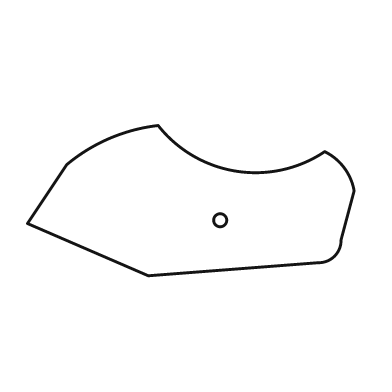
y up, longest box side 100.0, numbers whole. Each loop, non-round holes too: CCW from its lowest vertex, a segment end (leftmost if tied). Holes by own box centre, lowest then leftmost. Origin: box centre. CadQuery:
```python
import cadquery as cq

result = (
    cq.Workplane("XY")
    .moveTo(-13.0, -23.0)
    .lineTo(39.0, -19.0)
    .threePointArc((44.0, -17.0), (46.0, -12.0))
    .lineTo(50.0, 3.0)
    .threePointArc((47.0, 10.0), (41.0, 15.0))
    .threePointArc((14.0, 9.0), (-10.0, 23.0))
    .threePointArc((-25.0, 19.0), (-38.0, 11.0))
    .lineTo(-50.0, -7.0)
    .close()
    .moveTo(9.0, -6.0)
    .circle(2.0)
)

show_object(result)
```